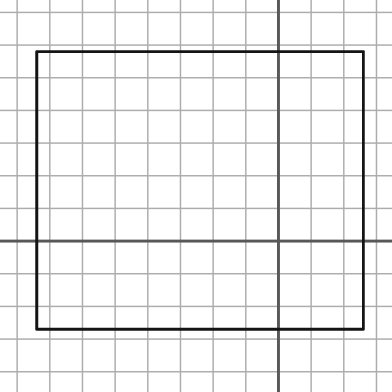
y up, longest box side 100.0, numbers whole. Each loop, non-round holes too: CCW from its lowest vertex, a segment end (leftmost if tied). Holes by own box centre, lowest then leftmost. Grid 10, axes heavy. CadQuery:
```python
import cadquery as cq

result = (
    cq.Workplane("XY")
    .moveTo(-74.0, -27.0)
    .lineTo(26.0, -27.0)
    .lineTo(26.0, 58.0)
    .lineTo(-74.0, 58.0)
    .close()
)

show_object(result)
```